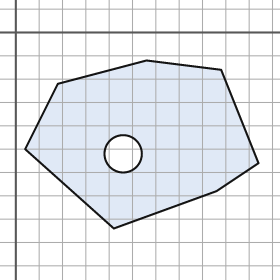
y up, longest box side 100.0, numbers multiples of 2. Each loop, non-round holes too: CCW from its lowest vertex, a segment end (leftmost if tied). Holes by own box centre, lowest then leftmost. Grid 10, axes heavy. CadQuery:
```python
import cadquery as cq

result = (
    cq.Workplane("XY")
    .moveTo(42.0, -84.0)
    .lineTo(86.0, -68.0)
    .lineTo(104.0, -56.0)
    .lineTo(88.0, -16.0)
    .lineTo(56.0, -12.0)
    .lineTo(18.0, -22.0)
    .lineTo(4.0, -50.0)
    .close()
    .moveTo(46.0, -52.0)
    .circle(8.0)
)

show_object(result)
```